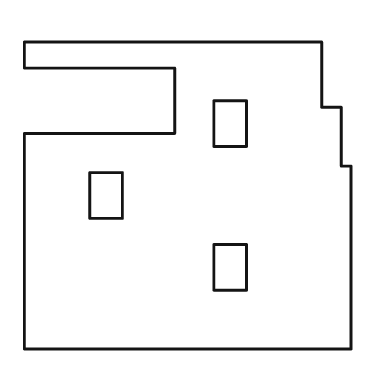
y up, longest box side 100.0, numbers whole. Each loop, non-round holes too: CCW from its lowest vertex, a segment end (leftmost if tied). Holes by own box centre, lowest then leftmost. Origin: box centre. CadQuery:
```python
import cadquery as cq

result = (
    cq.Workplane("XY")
    .moveTo(-50.0, -47.0)
    .lineTo(50.0, -47.0)
    .lineTo(50.0, 9.0)
    .lineTo(47.0, 9.0)
    .lineTo(47.0, 27.0)
    .lineTo(41.0, 27.0)
    .lineTo(41.0, 47.0)
    .lineTo(-50.0, 47.0)
    .lineTo(-50.0, 39.0)
    .lineTo(-4.0, 39.0)
    .lineTo(-4.0, 19.0)
    .lineTo(-50.0, 19.0)
    .close()
    .moveTo(8.0, -29.0)
    .lineTo(18.0, -29.0)
    .lineTo(18.0, -15.0)
    .lineTo(8.0, -15.0)
    .close()
    .moveTo(-30.0, -7.0)
    .lineTo(-20.0, -7.0)
    .lineTo(-20.0, 7.0)
    .lineTo(-30.0, 7.0)
    .close()
    .moveTo(8.0, 15.0)
    .lineTo(18.0, 15.0)
    .lineTo(18.0, 29.0)
    .lineTo(8.0, 29.0)
    .close()
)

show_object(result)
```